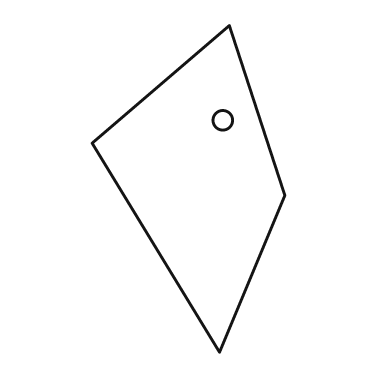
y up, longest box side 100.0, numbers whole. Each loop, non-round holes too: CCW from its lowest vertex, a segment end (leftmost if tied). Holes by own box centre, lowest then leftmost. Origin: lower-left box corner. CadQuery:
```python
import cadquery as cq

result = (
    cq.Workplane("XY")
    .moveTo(39.0, 0.0)
    .lineTo(59.0, 48.0)
    .lineTo(42.0, 100.0)
    .lineTo(0.0, 64.0)
    .close()
    .moveTo(40.0, 71.0)
    .circle(3.0)
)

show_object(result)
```